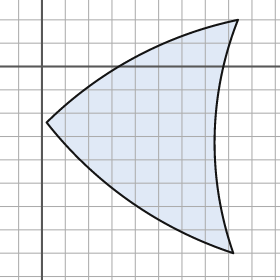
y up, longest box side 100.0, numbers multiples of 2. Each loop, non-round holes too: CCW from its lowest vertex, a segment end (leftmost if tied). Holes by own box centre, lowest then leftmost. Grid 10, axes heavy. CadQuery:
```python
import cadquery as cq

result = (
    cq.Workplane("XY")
    .moveTo(82.0, -80.0)
    .threePointArc((74.0, -30.0), (84.0, 20.0))
    .threePointArc((40.0, 4.0), (2.0, -24.0))
    .threePointArc((38.0, -58.0), (82.0, -80.0))
    .close()
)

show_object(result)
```